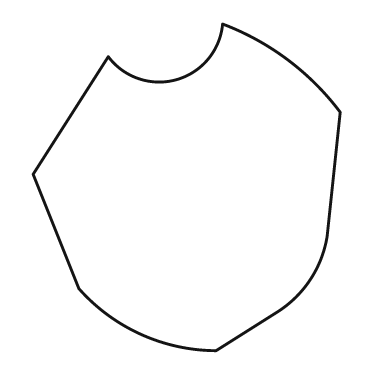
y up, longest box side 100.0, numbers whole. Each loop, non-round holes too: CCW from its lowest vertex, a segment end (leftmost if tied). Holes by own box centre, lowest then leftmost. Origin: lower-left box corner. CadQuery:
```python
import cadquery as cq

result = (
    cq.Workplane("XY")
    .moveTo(56.0, 0.0)
    .lineTo(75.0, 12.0)
    .threePointArc((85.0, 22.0), (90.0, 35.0))
    .lineTo(94.0, 73.0)
    .threePointArc((78.0, 89.0), (58.0, 100.0))
    .threePointArc((44.0, 83.0), (23.0, 90.0))
    .lineTo(0.0, 54.0)
    .lineTo(14.0, 19.0)
    .threePointArc((33.0, 5.0), (56.0, 0.0))
    .close()
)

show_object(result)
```